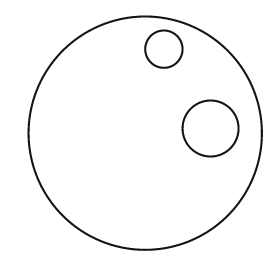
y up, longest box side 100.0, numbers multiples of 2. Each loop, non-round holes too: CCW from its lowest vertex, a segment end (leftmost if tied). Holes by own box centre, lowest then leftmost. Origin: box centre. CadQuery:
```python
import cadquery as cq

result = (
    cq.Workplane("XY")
    .moveTo(0.0, 0.0)
    .circle(50.0)
    .moveTo(28.0, 2.0)
    .circle(12.0)
    .moveTo(8.0, 36.0)
    .circle(8.0)
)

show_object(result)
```